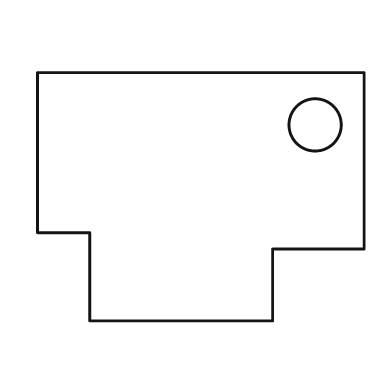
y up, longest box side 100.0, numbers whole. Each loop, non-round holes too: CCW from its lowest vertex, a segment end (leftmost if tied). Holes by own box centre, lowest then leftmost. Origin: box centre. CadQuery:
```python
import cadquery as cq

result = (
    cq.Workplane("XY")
    .moveTo(-34.0, -38.0)
    .lineTo(22.0, -38.0)
    .lineTo(22.0, -16.0)
    .lineTo(50.0, -16.0)
    .lineTo(50.0, 38.0)
    .lineTo(-50.0, 38.0)
    .lineTo(-50.0, -11.0)
    .lineTo(-34.0, -11.0)
    .close()
    .moveTo(35.0, 22.0)
    .circle(8.0)
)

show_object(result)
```